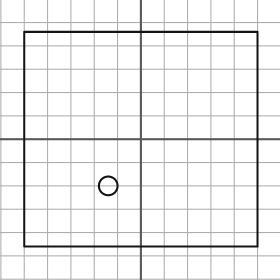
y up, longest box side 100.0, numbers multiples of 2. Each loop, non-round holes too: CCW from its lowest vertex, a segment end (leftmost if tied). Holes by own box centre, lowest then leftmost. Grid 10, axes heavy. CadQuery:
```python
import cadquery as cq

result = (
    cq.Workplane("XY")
    .moveTo(-50.0, -46.0)
    .lineTo(50.0, -46.0)
    .lineTo(50.0, 46.0)
    .lineTo(-50.0, 46.0)
    .close()
    .moveTo(-14.0, -20.0)
    .circle(4.0)
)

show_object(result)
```